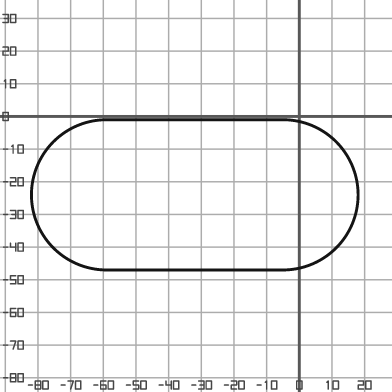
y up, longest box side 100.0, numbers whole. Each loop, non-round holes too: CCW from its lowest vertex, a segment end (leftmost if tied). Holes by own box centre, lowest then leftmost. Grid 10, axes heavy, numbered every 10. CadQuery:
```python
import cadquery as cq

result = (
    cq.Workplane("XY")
    .moveTo(-59.0, -47.0)
    .lineTo(-5.0, -47.0)
    .threePointArc((18.0, -24.0), (-5.0, -1.0))
    .lineTo(-59.0, -1.0)
    .threePointArc((-82.0, -24.0), (-59.0, -47.0))
    .close()
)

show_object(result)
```